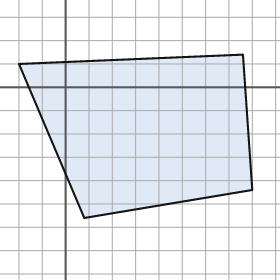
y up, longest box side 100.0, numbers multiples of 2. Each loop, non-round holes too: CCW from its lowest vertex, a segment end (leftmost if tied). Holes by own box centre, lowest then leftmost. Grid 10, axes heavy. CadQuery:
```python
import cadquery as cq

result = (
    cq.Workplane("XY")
    .moveTo(8.0, -56.0)
    .lineTo(80.0, -44.0)
    .lineTo(76.0, 14.0)
    .lineTo(-20.0, 10.0)
    .close()
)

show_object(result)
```